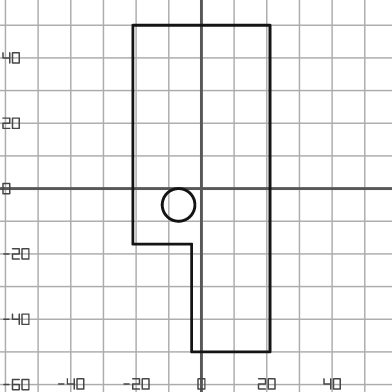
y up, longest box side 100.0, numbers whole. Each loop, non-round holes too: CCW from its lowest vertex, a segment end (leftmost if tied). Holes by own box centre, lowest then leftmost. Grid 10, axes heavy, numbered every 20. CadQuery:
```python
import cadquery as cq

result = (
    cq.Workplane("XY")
    .moveTo(-3.0, -50.0)
    .lineTo(21.0, -50.0)
    .lineTo(21.0, 50.0)
    .lineTo(-21.0, 50.0)
    .lineTo(-21.0, -17.0)
    .lineTo(-3.0, -17.0)
    .close()
    .moveTo(-7.0, -5.0)
    .circle(5.0)
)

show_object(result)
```